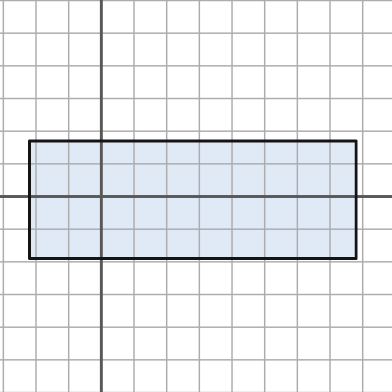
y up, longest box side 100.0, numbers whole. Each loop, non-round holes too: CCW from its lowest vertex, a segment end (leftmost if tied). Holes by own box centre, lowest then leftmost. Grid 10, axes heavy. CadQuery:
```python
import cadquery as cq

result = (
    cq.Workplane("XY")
    .moveTo(-22.0, -19.0)
    .lineTo(78.0, -19.0)
    .lineTo(78.0, 17.0)
    .lineTo(-22.0, 17.0)
    .close()
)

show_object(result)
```